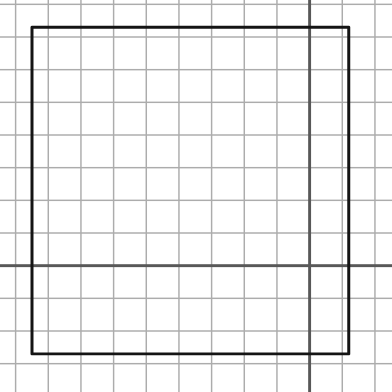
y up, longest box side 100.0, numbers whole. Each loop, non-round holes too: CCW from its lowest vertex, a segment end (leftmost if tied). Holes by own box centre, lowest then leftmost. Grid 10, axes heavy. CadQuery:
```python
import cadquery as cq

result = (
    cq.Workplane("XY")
    .moveTo(-85.0, -27.0)
    .lineTo(12.0, -27.0)
    .lineTo(12.0, 73.0)
    .lineTo(-85.0, 73.0)
    .close()
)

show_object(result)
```